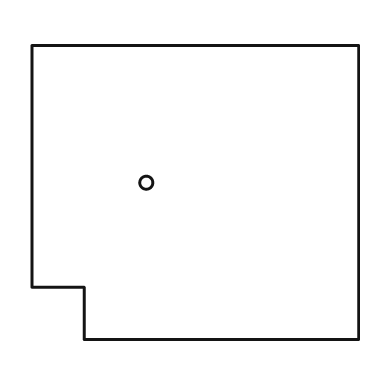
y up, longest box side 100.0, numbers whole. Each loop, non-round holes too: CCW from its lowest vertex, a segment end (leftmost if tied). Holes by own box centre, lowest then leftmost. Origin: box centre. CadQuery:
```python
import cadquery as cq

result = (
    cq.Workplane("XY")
    .moveTo(-34.0, -45.0)
    .lineTo(50.0, -45.0)
    .lineTo(50.0, 45.0)
    .lineTo(-50.0, 45.0)
    .lineTo(-50.0, -29.0)
    .lineTo(-34.0, -29.0)
    .close()
    .moveTo(-15.0, 3.0)
    .circle(2.0)
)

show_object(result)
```